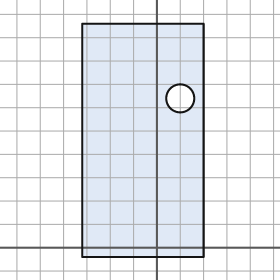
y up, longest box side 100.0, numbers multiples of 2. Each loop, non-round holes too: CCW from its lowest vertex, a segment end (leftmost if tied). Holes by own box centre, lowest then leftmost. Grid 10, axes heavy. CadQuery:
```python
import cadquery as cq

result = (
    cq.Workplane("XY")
    .moveTo(-32.0, -4.0)
    .lineTo(20.0, -4.0)
    .lineTo(20.0, 96.0)
    .lineTo(-32.0, 96.0)
    .close()
    .moveTo(10.0, 64.0)
    .circle(6.0)
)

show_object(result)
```